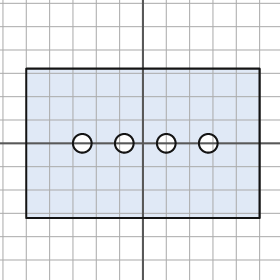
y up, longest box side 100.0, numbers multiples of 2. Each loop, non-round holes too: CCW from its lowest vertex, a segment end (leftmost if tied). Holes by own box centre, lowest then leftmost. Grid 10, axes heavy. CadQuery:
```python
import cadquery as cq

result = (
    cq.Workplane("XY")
    .moveTo(-50.0, -32.0)
    .lineTo(50.0, -32.0)
    .lineTo(50.0, 32.0)
    .lineTo(-50.0, 32.0)
    .close()
    .moveTo(-26.0, 0.0)
    .circle(4.0)
    .moveTo(-8.0, 0.0)
    .circle(4.0)
    .moveTo(10.0, 0.0)
    .circle(4.0)
    .moveTo(28.0, 0.0)
    .circle(4.0)
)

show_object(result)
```